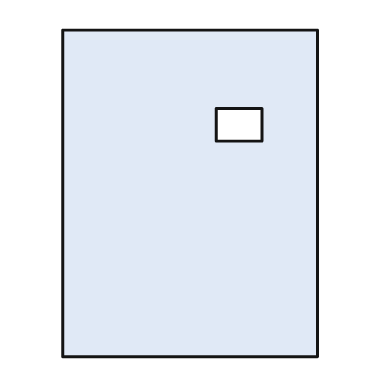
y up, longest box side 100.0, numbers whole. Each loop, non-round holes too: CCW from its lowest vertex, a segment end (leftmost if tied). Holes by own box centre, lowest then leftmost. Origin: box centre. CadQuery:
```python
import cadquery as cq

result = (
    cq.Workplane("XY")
    .moveTo(-39.0, -50.0)
    .lineTo(39.0, -50.0)
    .lineTo(39.0, 50.0)
    .lineTo(-39.0, 50.0)
    .close()
    .moveTo(8.0, 16.0)
    .lineTo(22.0, 16.0)
    .lineTo(22.0, 26.0)
    .lineTo(8.0, 26.0)
    .close()
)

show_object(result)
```